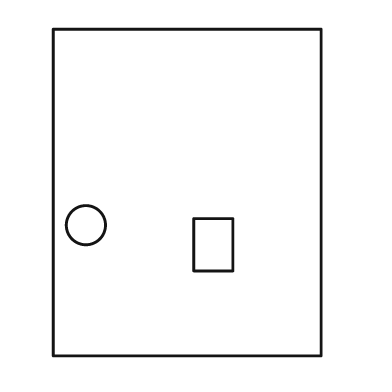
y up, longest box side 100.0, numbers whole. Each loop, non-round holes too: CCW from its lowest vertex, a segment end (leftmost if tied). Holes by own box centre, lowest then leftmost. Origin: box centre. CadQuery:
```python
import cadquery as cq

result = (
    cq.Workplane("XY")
    .moveTo(-41.0, -50.0)
    .lineTo(41.0, -50.0)
    .lineTo(41.0, 50.0)
    .lineTo(-41.0, 50.0)
    .close()
    .moveTo(2.0, -24.0)
    .lineTo(14.0, -24.0)
    .lineTo(14.0, -8.0)
    .lineTo(2.0, -8.0)
    .close()
    .moveTo(-31.0, -10.0)
    .circle(6.0)
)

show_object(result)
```